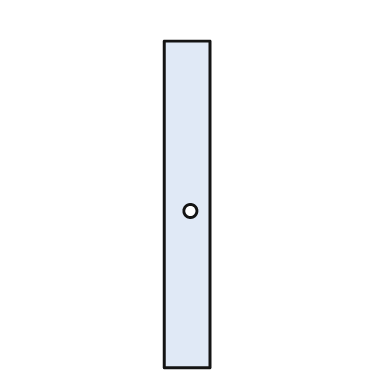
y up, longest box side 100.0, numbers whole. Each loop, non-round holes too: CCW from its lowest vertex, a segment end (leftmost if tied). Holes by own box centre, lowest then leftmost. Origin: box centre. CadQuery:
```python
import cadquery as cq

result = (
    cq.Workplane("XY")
    .moveTo(-7.0, -50.0)
    .lineTo(7.0, -50.0)
    .lineTo(7.0, 50.0)
    .lineTo(-7.0, 50.0)
    .close()
    .moveTo(1.0, -2.0)
    .circle(2.0)
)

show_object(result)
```